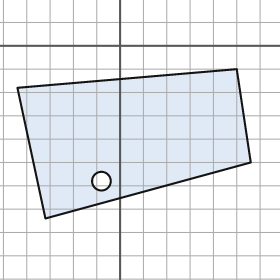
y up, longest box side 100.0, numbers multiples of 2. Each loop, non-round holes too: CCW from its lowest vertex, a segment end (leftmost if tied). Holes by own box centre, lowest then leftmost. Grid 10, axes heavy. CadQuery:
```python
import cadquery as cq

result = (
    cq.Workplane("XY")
    .moveTo(-32.0, -74.0)
    .lineTo(56.0, -50.0)
    .lineTo(50.0, -10.0)
    .lineTo(-44.0, -18.0)
    .close()
    .moveTo(-8.0, -58.0)
    .circle(4.0)
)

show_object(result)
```